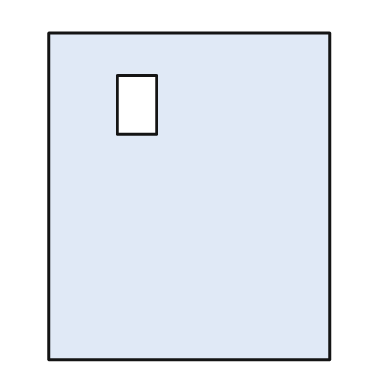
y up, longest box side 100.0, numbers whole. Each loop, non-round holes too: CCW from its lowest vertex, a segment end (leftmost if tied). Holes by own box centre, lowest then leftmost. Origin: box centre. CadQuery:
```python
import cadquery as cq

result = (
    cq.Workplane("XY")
    .moveTo(-43.0, -50.0)
    .lineTo(43.0, -50.0)
    .lineTo(43.0, 50.0)
    .lineTo(-43.0, 50.0)
    .close()
    .moveTo(-22.0, 19.0)
    .lineTo(-10.0, 19.0)
    .lineTo(-10.0, 37.0)
    .lineTo(-22.0, 37.0)
    .close()
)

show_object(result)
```